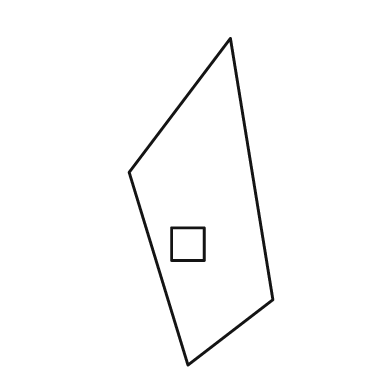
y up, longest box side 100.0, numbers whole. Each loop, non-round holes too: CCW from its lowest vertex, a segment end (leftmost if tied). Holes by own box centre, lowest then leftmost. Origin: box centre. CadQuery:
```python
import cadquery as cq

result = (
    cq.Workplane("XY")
    .moveTo(-4.0, -50.0)
    .lineTo(22.0, -30.0)
    .lineTo(9.0, 50.0)
    .lineTo(-22.0, 9.0)
    .close()
    .moveTo(-9.0, -18.0)
    .lineTo(1.0, -18.0)
    .lineTo(1.0, -8.0)
    .lineTo(-9.0, -8.0)
    .close()
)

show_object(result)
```